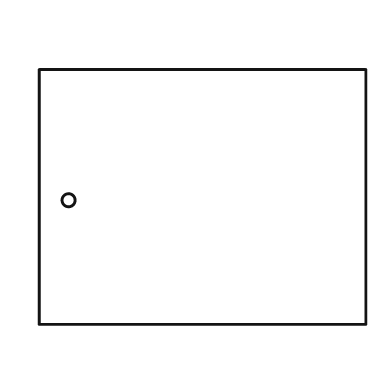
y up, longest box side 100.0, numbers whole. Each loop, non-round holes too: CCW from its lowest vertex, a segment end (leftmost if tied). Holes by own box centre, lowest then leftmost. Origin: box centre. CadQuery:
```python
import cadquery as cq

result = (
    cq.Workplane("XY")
    .moveTo(-50.0, -39.0)
    .lineTo(50.0, -39.0)
    .lineTo(50.0, 39.0)
    .lineTo(-50.0, 39.0)
    .close()
    .moveTo(-41.0, -1.0)
    .circle(2.0)
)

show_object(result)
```